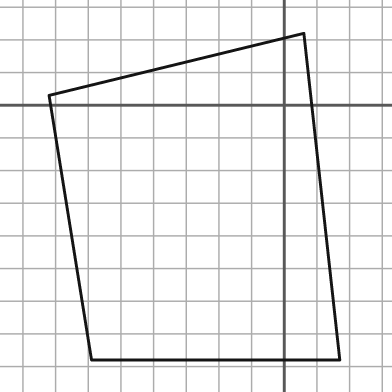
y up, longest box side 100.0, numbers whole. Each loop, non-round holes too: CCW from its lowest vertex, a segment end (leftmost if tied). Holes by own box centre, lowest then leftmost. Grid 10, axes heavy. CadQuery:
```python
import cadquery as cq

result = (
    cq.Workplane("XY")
    .moveTo(-59.0, -78.0)
    .lineTo(17.0, -78.0)
    .lineTo(6.0, 22.0)
    .lineTo(-72.0, 3.0)
    .close()
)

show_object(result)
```